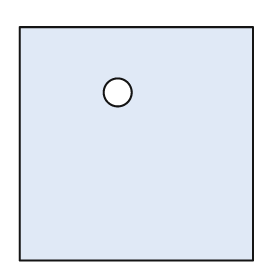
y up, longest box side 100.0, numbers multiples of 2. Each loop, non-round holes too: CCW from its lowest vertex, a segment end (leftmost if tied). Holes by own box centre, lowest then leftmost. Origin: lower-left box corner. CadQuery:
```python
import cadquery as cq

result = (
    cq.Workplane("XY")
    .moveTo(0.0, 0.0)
    .lineTo(100.0, 0.0)
    .lineTo(100.0, 100.0)
    .lineTo(0.0, 100.0)
    .close()
    .moveTo(42.0, 72.0)
    .circle(6.0)
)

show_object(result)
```